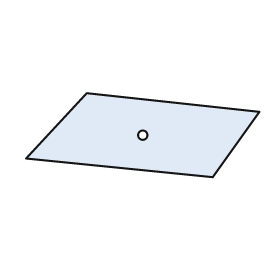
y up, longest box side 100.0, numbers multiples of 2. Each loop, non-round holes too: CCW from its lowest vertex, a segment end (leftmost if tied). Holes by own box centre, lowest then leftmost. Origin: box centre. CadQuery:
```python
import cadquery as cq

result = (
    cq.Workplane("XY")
    .moveTo(30.0, -18.0)
    .lineTo(50.0, 10.0)
    .lineTo(-24.0, 18.0)
    .lineTo(-50.0, -10.0)
    .close()
    .moveTo(0.0, 0.0)
    .circle(2.0)
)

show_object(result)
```